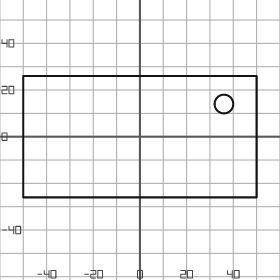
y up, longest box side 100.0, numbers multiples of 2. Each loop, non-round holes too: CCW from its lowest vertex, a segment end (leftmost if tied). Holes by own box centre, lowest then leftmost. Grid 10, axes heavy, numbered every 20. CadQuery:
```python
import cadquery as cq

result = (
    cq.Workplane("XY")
    .moveTo(-50.0, -26.0)
    .lineTo(50.0, -26.0)
    .lineTo(50.0, 26.0)
    .lineTo(-50.0, 26.0)
    .close()
    .moveTo(36.0, 14.0)
    .circle(4.0)
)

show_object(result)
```